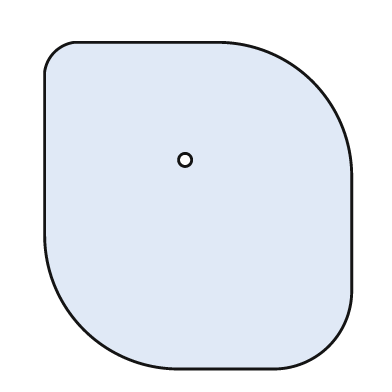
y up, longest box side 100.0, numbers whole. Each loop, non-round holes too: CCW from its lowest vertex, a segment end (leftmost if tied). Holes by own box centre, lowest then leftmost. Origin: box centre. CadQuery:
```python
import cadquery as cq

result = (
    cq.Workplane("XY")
    .moveTo(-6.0, -50.0)
    .lineTo(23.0, -50.0)
    .threePointArc((40.0, -43.0), (47.0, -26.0))
    .lineTo(47.0, 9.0)
    .threePointArc((35.0, 38.0), (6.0, 50.0))
    .lineTo(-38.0, 50.0)
    .threePointArc((-44.0, 47.0), (-47.0, 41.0))
    .lineTo(-47.0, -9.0)
    .threePointArc((-35.0, -38.0), (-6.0, -50.0))
    .close()
    .moveTo(-4.0, 14.0)
    .circle(2.0)
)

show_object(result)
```